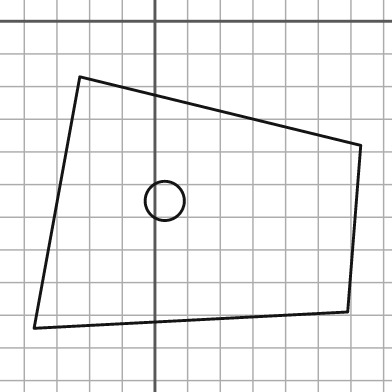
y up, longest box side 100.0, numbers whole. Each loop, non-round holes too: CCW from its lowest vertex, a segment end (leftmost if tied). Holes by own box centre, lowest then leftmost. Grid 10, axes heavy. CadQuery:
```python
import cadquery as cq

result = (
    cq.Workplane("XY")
    .moveTo(-37.0, -94.0)
    .lineTo(59.0, -89.0)
    .lineTo(63.0, -38.0)
    .lineTo(-23.0, -17.0)
    .close()
    .moveTo(3.0, -55.0)
    .circle(6.0)
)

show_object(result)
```